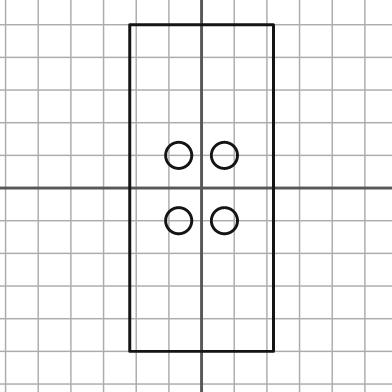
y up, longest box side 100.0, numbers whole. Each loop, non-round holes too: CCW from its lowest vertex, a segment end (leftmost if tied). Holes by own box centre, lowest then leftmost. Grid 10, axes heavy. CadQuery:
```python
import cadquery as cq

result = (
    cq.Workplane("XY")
    .moveTo(-22.0, -50.0)
    .lineTo(22.0, -50.0)
    .lineTo(22.0, 50.0)
    .lineTo(-22.0, 50.0)
    .close()
    .moveTo(-7.0, -10.0)
    .circle(4.0)
    .moveTo(7.0, -10.0)
    .circle(4.0)
    .moveTo(-7.0, 10.0)
    .circle(4.0)
    .moveTo(7.0, 10.0)
    .circle(4.0)
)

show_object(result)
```